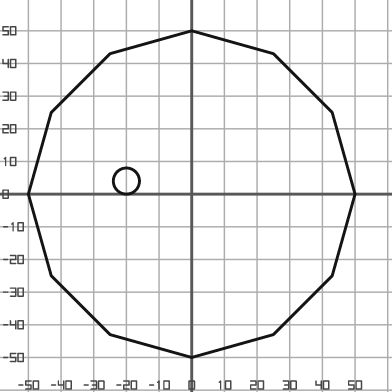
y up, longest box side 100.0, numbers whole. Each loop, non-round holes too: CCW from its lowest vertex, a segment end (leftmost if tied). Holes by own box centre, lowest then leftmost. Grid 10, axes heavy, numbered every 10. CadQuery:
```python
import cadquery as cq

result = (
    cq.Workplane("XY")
    .moveTo(0.0, -50.0)
    .lineTo(25.0, -43.0)
    .lineTo(43.0, -25.0)
    .lineTo(50.0, 0.0)
    .lineTo(43.0, 25.0)
    .lineTo(25.0, 43.0)
    .lineTo(0.0, 50.0)
    .lineTo(-25.0, 43.0)
    .lineTo(-43.0, 25.0)
    .lineTo(-50.0, 0.0)
    .lineTo(-43.0, -25.0)
    .lineTo(-25.0, -43.0)
    .close()
    .moveTo(-20.0, 4.0)
    .circle(4.0)
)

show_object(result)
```